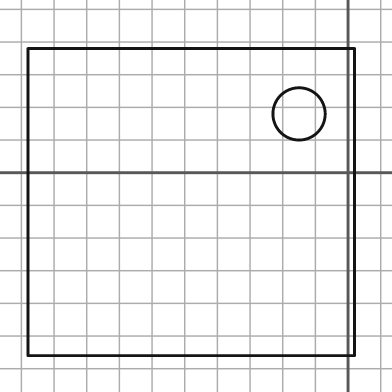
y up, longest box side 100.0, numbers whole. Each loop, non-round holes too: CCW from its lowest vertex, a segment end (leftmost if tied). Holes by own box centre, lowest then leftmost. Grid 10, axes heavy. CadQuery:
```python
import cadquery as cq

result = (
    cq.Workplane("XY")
    .moveTo(-98.0, -56.0)
    .lineTo(2.0, -56.0)
    .lineTo(2.0, 38.0)
    .lineTo(-98.0, 38.0)
    .close()
    .moveTo(-15.0, 18.0)
    .circle(8.0)
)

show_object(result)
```